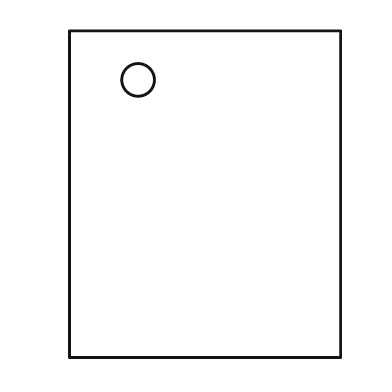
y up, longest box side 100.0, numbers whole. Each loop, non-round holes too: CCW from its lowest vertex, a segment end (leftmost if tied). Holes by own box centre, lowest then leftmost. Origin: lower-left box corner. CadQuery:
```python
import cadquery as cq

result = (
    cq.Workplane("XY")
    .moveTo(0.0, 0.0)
    .lineTo(83.0, 0.0)
    .lineTo(83.0, 100.0)
    .lineTo(0.0, 100.0)
    .close()
    .moveTo(21.0, 85.0)
    .circle(5.0)
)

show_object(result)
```